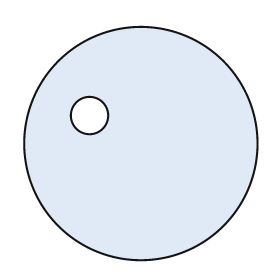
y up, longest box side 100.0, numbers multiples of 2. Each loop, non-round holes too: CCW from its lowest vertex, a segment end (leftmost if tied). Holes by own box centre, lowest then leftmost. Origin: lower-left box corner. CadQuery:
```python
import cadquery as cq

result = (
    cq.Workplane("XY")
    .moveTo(50.0, 50.0)
    .circle(50.0)
    .moveTo(28.0, 62.0)
    .circle(8.0)
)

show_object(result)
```